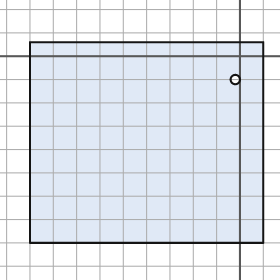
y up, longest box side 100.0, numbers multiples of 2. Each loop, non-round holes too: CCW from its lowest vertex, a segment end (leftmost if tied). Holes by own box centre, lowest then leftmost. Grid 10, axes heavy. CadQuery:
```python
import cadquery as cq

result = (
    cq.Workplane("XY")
    .moveTo(-90.0, -80.0)
    .lineTo(10.0, -80.0)
    .lineTo(10.0, 6.0)
    .lineTo(-90.0, 6.0)
    .close()
    .moveTo(-2.0, -10.0)
    .circle(2.0)
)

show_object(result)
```